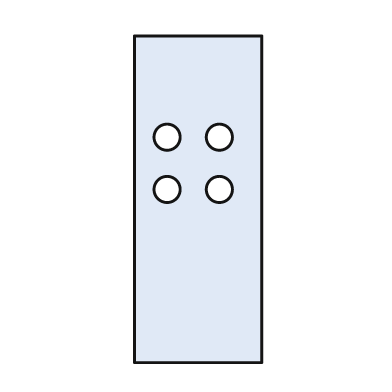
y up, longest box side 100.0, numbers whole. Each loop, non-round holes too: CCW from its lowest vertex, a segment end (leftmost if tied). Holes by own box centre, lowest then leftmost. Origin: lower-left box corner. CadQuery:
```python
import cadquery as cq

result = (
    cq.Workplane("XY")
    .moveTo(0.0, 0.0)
    .lineTo(39.0, 0.0)
    .lineTo(39.0, 100.0)
    .lineTo(0.0, 100.0)
    .close()
    .moveTo(10.0, 53.0)
    .circle(4.0)
    .moveTo(26.0, 53.0)
    .circle(4.0)
    .moveTo(10.0, 69.0)
    .circle(4.0)
    .moveTo(26.0, 69.0)
    .circle(4.0)
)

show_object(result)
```